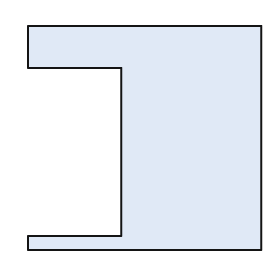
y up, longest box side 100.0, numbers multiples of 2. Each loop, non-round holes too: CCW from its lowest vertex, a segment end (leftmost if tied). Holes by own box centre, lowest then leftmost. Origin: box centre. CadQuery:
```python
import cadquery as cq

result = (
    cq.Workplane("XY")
    .moveTo(-50.0, -48.0)
    .lineTo(50.0, -48.0)
    .lineTo(50.0, 48.0)
    .lineTo(-50.0, 48.0)
    .lineTo(-50.0, 30.0)
    .lineTo(-10.0, 30.0)
    .lineTo(-10.0, -42.0)
    .lineTo(-50.0, -42.0)
    .close()
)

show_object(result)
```